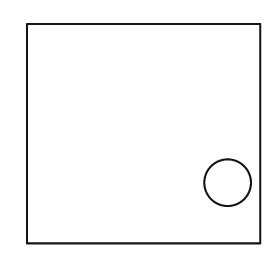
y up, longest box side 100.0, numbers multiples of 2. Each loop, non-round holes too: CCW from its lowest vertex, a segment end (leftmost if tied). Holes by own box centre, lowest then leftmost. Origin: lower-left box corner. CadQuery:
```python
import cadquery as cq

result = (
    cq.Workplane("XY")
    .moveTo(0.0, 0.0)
    .lineTo(100.0, 0.0)
    .lineTo(100.0, 94.0)
    .lineTo(0.0, 94.0)
    .close()
    .moveTo(86.0, 26.0)
    .circle(10.0)
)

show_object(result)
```